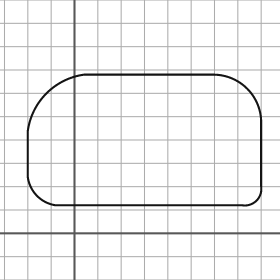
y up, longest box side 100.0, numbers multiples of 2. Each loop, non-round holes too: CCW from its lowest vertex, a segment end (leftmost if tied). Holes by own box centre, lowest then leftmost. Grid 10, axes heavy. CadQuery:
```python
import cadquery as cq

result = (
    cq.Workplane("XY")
    .moveTo(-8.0, 12.0)
    .lineTo(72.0, 12.0)
    .threePointArc((78.0, 14.0), (80.0, 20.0))
    .lineTo(80.0, 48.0)
    .threePointArc((74.0, 62.0), (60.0, 68.0))
    .lineTo(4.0, 68.0)
    .threePointArc((-12.0, 60.0), (-20.0, 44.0))
    .lineTo(-20.0, 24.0)
    .threePointArc((-16.0, 16.0), (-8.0, 12.0))
    .close()
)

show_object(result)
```